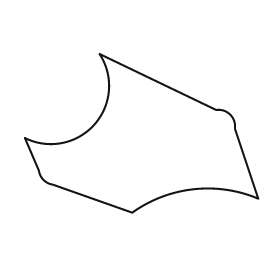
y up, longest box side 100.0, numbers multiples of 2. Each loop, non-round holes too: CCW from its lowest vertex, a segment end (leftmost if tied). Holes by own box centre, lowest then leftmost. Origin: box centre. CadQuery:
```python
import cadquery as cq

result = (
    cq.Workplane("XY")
    .moveTo(-4.0, -34.0)
    .threePointArc((22.0, -24.0), (50.0, -28.0))
    .lineTo(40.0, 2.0)
    .threePointArc((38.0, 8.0), (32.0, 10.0))
    .lineTo(-18.0, 34.0)
    .threePointArc((-20.0, 4.0), (-50.0, -2.0))
    .lineTo(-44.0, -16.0)
    .threePointArc((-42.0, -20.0), (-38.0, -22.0))
    .close()
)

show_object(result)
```